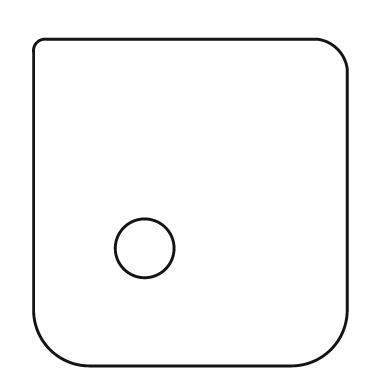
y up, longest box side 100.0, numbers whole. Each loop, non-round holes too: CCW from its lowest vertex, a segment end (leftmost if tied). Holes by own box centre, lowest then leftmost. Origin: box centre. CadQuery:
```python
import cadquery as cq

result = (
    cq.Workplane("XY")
    .moveTo(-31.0, -50.0)
    .lineTo(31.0, -50.0)
    .threePointArc((43.0, -45.0), (48.0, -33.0))
    .lineTo(48.0, 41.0)
    .threePointArc((45.0, 47.0), (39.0, 50.0))
    .lineTo(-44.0, 50.0)
    .threePointArc((-47.0, 49.0), (-48.0, 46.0))
    .lineTo(-48.0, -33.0)
    .threePointArc((-43.0, -45.0), (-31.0, -50.0))
    .close()
    .moveTo(-14.0, -14.0)
    .circle(9.0)
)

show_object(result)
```